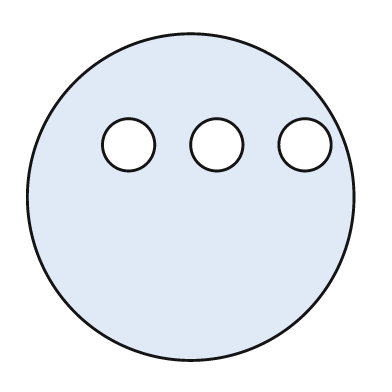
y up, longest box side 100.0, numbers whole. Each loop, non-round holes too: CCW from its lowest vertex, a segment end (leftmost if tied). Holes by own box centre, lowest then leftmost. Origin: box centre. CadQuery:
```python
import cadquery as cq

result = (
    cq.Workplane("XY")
    .moveTo(0.0, 0.0)
    .circle(50.0)
    .moveTo(-19.0, 16.0)
    .circle(8.0)
    .moveTo(8.0, 16.0)
    .circle(8.0)
    .moveTo(35.0, 16.0)
    .circle(8.0)
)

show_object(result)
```